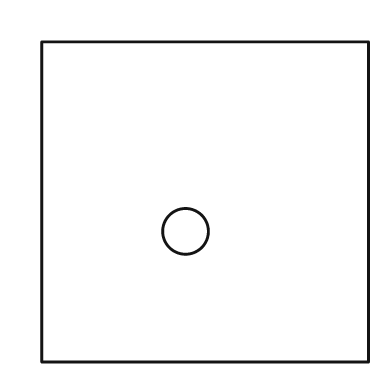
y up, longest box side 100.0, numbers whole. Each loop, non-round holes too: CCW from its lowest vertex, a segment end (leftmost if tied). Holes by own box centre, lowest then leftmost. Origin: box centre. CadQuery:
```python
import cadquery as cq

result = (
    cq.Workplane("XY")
    .moveTo(-50.0, -49.0)
    .lineTo(50.0, -49.0)
    .lineTo(50.0, 49.0)
    .lineTo(-50.0, 49.0)
    .close()
    .moveTo(-6.0, -9.0)
    .circle(7.0)
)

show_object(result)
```